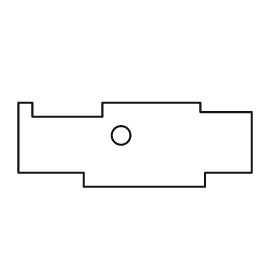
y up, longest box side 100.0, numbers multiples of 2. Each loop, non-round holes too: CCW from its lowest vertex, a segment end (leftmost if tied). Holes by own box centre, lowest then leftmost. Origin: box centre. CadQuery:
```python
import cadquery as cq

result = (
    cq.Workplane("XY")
    .moveTo(-22.0, -18.0)
    .lineTo(30.0, -18.0)
    .lineTo(30.0, -12.0)
    .lineTo(50.0, -12.0)
    .lineTo(50.0, 14.0)
    .lineTo(28.0, 14.0)
    .lineTo(28.0, 18.0)
    .lineTo(-14.0, 18.0)
    .lineTo(-14.0, 12.0)
    .lineTo(-44.0, 12.0)
    .lineTo(-44.0, 18.0)
    .lineTo(-50.0, 18.0)
    .lineTo(-50.0, -12.0)
    .lineTo(-22.0, -12.0)
    .close()
    .moveTo(-6.0, 4.0)
    .circle(4.0)
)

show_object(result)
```